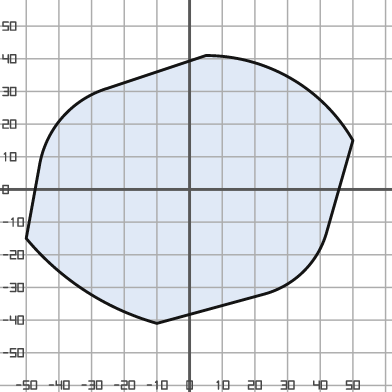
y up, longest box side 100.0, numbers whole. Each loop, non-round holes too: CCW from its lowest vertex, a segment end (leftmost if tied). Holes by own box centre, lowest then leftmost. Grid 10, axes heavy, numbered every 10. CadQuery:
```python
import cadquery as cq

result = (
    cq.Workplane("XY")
    .moveTo(-10.0, -41.0)
    .lineTo(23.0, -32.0)
    .threePointArc((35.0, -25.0), (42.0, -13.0))
    .lineTo(50.0, 15.0)
    .threePointArc((31.0, 34.0), (5.0, 41.0))
    .lineTo(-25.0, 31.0)
    .threePointArc((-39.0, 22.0), (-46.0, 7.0))
    .lineTo(-50.0, -15.0)
    .threePointArc((-32.0, -31.0), (-10.0, -41.0))
    .close()
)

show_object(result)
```